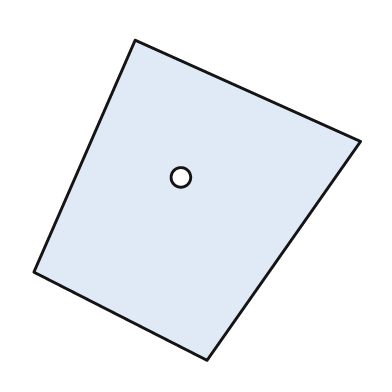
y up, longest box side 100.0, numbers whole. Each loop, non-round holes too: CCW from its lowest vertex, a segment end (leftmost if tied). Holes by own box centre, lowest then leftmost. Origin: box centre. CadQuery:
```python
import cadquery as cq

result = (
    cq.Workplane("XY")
    .moveTo(3.0, -49.0)
    .lineTo(50.0, 18.0)
    .lineTo(-19.0, 49.0)
    .lineTo(-50.0, -22.0)
    .close()
    .moveTo(-5.0, 7.0)
    .circle(3.0)
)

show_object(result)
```